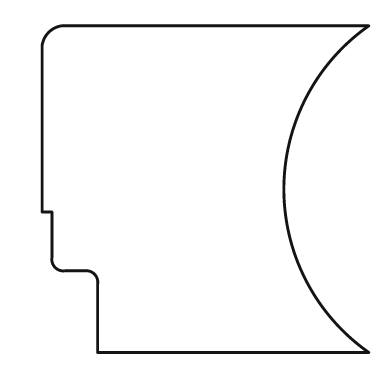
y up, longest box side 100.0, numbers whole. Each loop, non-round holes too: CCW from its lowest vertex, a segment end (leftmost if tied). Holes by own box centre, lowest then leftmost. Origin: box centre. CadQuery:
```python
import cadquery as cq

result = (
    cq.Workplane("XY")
    .moveTo(-33.0, -50.0)
    .lineTo(50.0, -50.0)
    .threePointArc((24.0, 0.0), (50.0, 50.0))
    .lineTo(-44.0, 50.0)
    .threePointArc((-48.0, 48.0), (-50.0, 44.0))
    .lineTo(-50.0, -7.0)
    .lineTo(-47.0, -7.0)
    .lineTo(-47.0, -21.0)
    .threePointArc((-46.0, -24.0), (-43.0, -25.0))
    .lineTo(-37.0, -25.0)
    .threePointArc((-34.0, -26.0), (-33.0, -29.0))
    .close()
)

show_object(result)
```